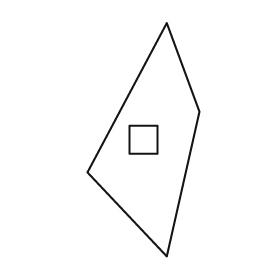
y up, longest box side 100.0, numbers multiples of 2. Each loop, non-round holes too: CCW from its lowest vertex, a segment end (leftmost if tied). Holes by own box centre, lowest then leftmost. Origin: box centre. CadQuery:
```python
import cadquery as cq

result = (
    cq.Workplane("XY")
    .moveTo(10.0, -50.0)
    .lineTo(24.0, 12.0)
    .lineTo(10.0, 50.0)
    .lineTo(-24.0, -14.0)
    .close()
    .moveTo(-6.0, -6.0)
    .lineTo(6.0, -6.0)
    .lineTo(6.0, 6.0)
    .lineTo(-6.0, 6.0)
    .close()
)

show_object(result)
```